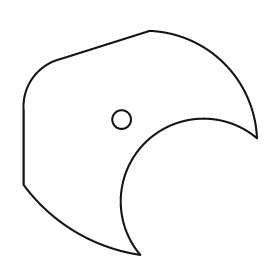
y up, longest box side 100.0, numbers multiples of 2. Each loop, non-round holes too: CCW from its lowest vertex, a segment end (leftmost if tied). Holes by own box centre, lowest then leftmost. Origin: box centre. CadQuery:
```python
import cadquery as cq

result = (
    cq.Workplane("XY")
    .moveTo(0.0, -48.0)
    .threePointArc((2.0, 0.0), (50.0, 2.0))
    .threePointArc((36.0, 34.0), (4.0, 48.0))
    .lineTo(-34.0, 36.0)
    .threePointArc((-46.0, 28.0), (-50.0, 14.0))
    .lineTo(-50.0, -18.0)
    .threePointArc((-28.0, -38.0), (0.0, -48.0))
    .close()
    .moveTo(-8.0, 10.0)
    .circle(4.0)
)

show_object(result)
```